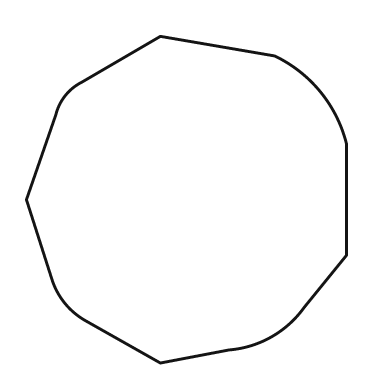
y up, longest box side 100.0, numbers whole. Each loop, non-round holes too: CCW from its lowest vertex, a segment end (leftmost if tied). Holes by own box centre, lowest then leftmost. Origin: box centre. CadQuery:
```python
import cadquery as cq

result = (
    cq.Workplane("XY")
    .moveTo(-8.0, -50.0)
    .lineTo(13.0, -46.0)
    .threePointArc((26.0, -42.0), (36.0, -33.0))
    .lineTo(49.0, -17.0)
    .lineTo(49.0, 17.0)
    .threePointArc((41.0, 33.0), (27.0, 44.0))
    .lineTo(-8.0, 50.0)
    .lineTo(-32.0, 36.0)
    .threePointArc((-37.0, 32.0), (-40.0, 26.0))
    .lineTo(-49.0, 0.0)
    .lineTo(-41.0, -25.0)
    .threePointArc((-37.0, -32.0), (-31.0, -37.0))
    .close()
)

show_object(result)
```